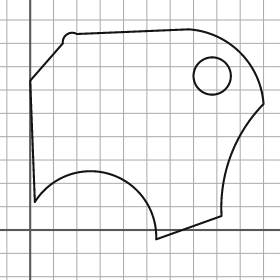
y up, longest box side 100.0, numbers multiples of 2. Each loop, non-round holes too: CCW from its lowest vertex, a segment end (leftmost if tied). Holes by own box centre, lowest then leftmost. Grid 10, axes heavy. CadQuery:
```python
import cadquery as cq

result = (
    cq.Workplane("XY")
    .moveTo(54.0, -4.0)
    .lineTo(82.0, 6.0)
    .threePointArc((86.0, 32.0), (100.0, 54.0))
    .threePointArc((90.0, 76.0), (68.0, 86.0))
    .lineTo(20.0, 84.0)
    .threePointArc((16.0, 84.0), (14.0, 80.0))
    .lineTo(0.0, 64.0)
    .lineTo(2.0, 12.0)
    .threePointArc((34.0, 24.0), (54.0, -4.0))
    .close()
    .moveTo(78.0, 66.0)
    .circle(8.0)
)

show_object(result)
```